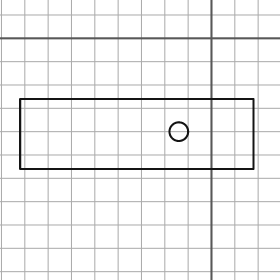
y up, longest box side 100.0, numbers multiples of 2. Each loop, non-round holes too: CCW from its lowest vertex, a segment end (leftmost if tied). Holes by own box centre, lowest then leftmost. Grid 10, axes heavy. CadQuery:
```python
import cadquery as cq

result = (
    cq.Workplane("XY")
    .moveTo(-82.0, -56.0)
    .lineTo(18.0, -56.0)
    .lineTo(18.0, -26.0)
    .lineTo(-82.0, -26.0)
    .close()
    .moveTo(-14.0, -40.0)
    .circle(4.0)
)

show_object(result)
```